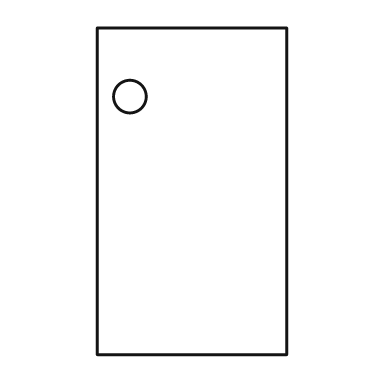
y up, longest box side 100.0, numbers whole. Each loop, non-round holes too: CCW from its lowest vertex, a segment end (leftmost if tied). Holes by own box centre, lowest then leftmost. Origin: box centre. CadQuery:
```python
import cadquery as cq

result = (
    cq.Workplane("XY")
    .moveTo(-29.0, -50.0)
    .lineTo(29.0, -50.0)
    .lineTo(29.0, 50.0)
    .lineTo(-29.0, 50.0)
    .close()
    .moveTo(-19.0, 29.0)
    .circle(5.0)
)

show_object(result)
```